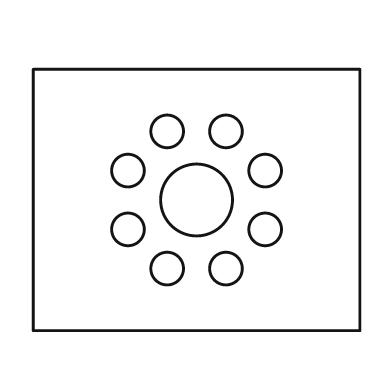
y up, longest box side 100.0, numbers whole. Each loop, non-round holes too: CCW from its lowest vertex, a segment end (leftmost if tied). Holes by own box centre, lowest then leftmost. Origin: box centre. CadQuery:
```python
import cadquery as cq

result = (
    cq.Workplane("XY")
    .moveTo(-50.0, -40.0)
    .lineTo(50.0, -40.0)
    .lineTo(50.0, 40.0)
    .lineTo(-50.0, 40.0)
    .close()
    .moveTo(-9.0, -21.0)
    .circle(5.0)
    .moveTo(9.0, -21.0)
    .circle(5.0)
    .moveTo(-21.0, -9.0)
    .circle(5.0)
    .moveTo(21.0, -9.0)
    .circle(5.0)
    .moveTo(0.0, 0.0)
    .circle(11.0)
    .moveTo(-21.0, 9.0)
    .circle(5.0)
    .moveTo(21.0, 9.0)
    .circle(5.0)
    .moveTo(-9.0, 21.0)
    .circle(5.0)
    .moveTo(9.0, 21.0)
    .circle(5.0)
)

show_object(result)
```